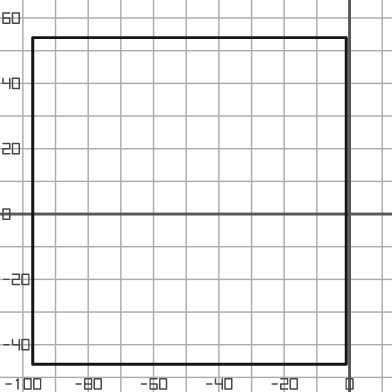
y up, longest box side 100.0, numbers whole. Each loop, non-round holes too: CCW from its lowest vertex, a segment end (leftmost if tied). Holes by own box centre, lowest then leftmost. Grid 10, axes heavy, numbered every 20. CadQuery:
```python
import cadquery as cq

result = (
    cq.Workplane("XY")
    .moveTo(-97.0, -46.0)
    .lineTo(-1.0, -46.0)
    .lineTo(-1.0, 54.0)
    .lineTo(-97.0, 54.0)
    .close()
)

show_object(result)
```